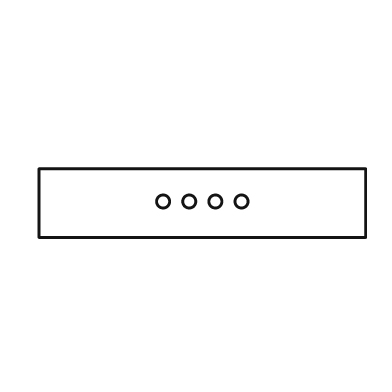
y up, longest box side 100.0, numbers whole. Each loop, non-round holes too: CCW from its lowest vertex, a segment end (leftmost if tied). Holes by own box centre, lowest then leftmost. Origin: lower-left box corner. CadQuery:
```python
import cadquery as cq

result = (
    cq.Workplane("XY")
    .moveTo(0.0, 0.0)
    .lineTo(100.0, 0.0)
    .lineTo(100.0, 21.0)
    .lineTo(0.0, 21.0)
    .close()
    .moveTo(38.0, 11.0)
    .circle(2.0)
    .moveTo(46.0, 11.0)
    .circle(2.0)
    .moveTo(54.0, 11.0)
    .circle(2.0)
    .moveTo(62.0, 11.0)
    .circle(2.0)
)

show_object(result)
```